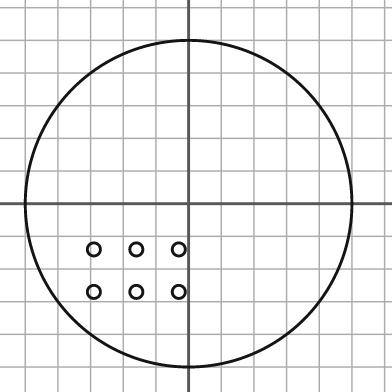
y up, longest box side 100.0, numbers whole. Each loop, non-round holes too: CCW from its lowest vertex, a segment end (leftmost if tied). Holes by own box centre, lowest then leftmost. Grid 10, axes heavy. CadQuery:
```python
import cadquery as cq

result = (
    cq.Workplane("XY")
    .moveTo(0.0, 0.0)
    .circle(50.0)
    .moveTo(-29.0, -27.0)
    .circle(2.0)
    .moveTo(-16.0, -27.0)
    .circle(2.0)
    .moveTo(-3.0, -27.0)
    .circle(2.0)
    .moveTo(-29.0, -14.0)
    .circle(2.0)
    .moveTo(-16.0, -14.0)
    .circle(2.0)
    .moveTo(-3.0, -14.0)
    .circle(2.0)
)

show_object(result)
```